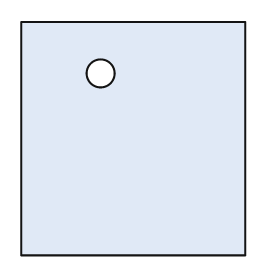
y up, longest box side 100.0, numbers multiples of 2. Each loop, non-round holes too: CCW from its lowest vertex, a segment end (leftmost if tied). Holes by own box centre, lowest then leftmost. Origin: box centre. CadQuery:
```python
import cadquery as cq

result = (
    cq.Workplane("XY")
    .moveTo(-48.0, -50.0)
    .lineTo(48.0, -50.0)
    .lineTo(48.0, 50.0)
    .lineTo(-48.0, 50.0)
    .close()
    .moveTo(-14.0, 28.0)
    .circle(6.0)
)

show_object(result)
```